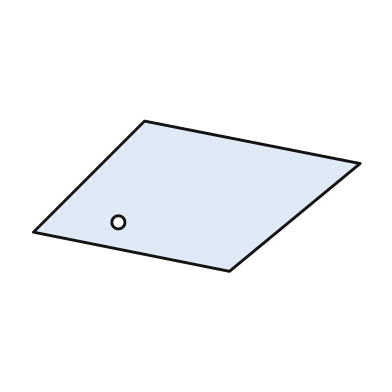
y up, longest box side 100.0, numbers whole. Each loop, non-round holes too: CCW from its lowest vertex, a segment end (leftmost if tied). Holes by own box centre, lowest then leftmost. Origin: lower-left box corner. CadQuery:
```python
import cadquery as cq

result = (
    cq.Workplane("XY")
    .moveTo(60.0, 0.0)
    .lineTo(100.0, 33.0)
    .lineTo(34.0, 46.0)
    .lineTo(0.0, 12.0)
    .close()
    .moveTo(26.0, 15.0)
    .circle(2.0)
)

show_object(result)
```